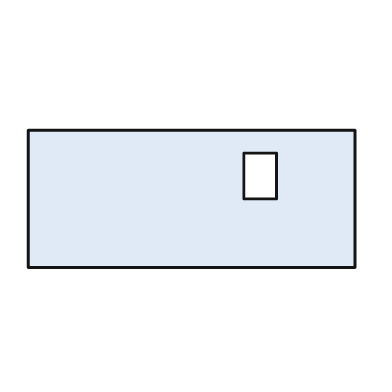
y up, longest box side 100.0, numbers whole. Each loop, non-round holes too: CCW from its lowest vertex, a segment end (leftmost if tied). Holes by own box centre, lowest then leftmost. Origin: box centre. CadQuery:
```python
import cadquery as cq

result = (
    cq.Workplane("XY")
    .moveTo(-50.0, -21.0)
    .lineTo(50.0, -21.0)
    .lineTo(50.0, 21.0)
    .lineTo(-50.0, 21.0)
    .close()
    .moveTo(16.0, 0.0)
    .lineTo(26.0, 0.0)
    .lineTo(26.0, 14.0)
    .lineTo(16.0, 14.0)
    .close()
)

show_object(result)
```